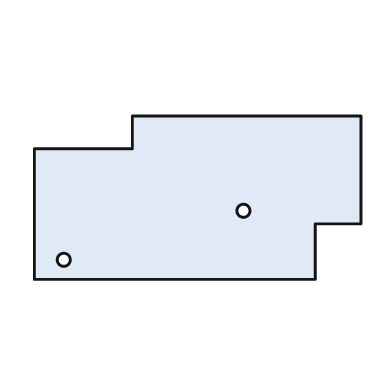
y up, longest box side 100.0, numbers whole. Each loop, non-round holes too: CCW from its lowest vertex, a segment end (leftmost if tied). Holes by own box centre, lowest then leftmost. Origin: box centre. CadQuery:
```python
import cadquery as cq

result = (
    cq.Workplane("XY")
    .moveTo(-50.0, -25.0)
    .lineTo(36.0, -25.0)
    .lineTo(36.0, -8.0)
    .lineTo(50.0, -8.0)
    .lineTo(50.0, 25.0)
    .lineTo(-20.0, 25.0)
    .lineTo(-20.0, 15.0)
    .lineTo(-50.0, 15.0)
    .close()
    .moveTo(-41.0, -19.0)
    .circle(2.0)
    .moveTo(14.0, -4.0)
    .circle(2.0)
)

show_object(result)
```